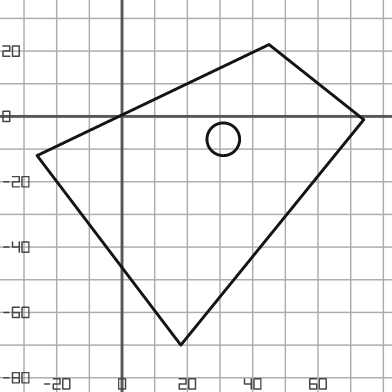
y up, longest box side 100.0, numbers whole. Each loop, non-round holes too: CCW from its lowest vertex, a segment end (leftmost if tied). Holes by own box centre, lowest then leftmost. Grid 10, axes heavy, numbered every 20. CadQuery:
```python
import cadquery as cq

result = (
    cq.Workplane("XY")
    .moveTo(18.0, -70.0)
    .lineTo(74.0, -1.0)
    .lineTo(45.0, 22.0)
    .lineTo(-26.0, -12.0)
    .close()
    .moveTo(31.0, -7.0)
    .circle(5.0)
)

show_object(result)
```